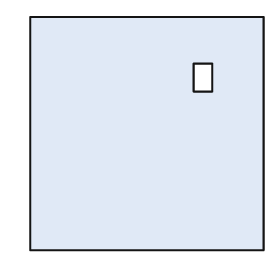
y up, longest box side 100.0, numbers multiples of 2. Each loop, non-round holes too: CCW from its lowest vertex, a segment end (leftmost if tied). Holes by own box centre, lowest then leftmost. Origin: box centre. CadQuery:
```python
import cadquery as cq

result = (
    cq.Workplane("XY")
    .moveTo(-50.0, -50.0)
    .lineTo(50.0, -50.0)
    .lineTo(50.0, 50.0)
    .lineTo(-50.0, 50.0)
    .close()
    .moveTo(20.0, 18.0)
    .lineTo(28.0, 18.0)
    .lineTo(28.0, 30.0)
    .lineTo(20.0, 30.0)
    .close()
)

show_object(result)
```